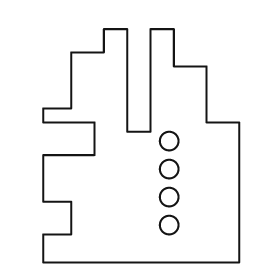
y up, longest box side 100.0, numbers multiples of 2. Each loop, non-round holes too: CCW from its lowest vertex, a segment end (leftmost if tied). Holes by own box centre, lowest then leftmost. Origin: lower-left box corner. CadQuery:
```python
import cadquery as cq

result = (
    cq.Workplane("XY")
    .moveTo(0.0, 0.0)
    .lineTo(84.0, 0.0)
    .lineTo(84.0, 60.0)
    .lineTo(70.0, 60.0)
    .lineTo(70.0, 84.0)
    .lineTo(56.0, 84.0)
    .lineTo(56.0, 100.0)
    .lineTo(46.0, 100.0)
    .lineTo(46.0, 56.0)
    .lineTo(36.0, 56.0)
    .lineTo(36.0, 100.0)
    .lineTo(26.0, 100.0)
    .lineTo(26.0, 90.0)
    .lineTo(12.0, 90.0)
    .lineTo(12.0, 66.0)
    .lineTo(0.0, 66.0)
    .lineTo(0.0, 60.0)
    .lineTo(22.0, 60.0)
    .lineTo(22.0, 46.0)
    .lineTo(0.0, 46.0)
    .lineTo(0.0, 26.0)
    .lineTo(12.0, 26.0)
    .lineTo(12.0, 12.0)
    .lineTo(0.0, 12.0)
    .close()
    .moveTo(54.0, 16.0)
    .circle(4.0)
    .moveTo(54.0, 28.0)
    .circle(4.0)
    .moveTo(54.0, 40.0)
    .circle(4.0)
    .moveTo(54.0, 52.0)
    .circle(4.0)
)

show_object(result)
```